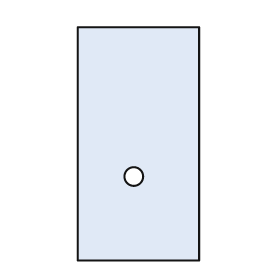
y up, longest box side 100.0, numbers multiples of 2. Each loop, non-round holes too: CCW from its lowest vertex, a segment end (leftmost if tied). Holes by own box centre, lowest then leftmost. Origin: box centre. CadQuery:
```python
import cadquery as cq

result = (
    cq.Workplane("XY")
    .moveTo(-26.0, -50.0)
    .lineTo(26.0, -50.0)
    .lineTo(26.0, 50.0)
    .lineTo(-26.0, 50.0)
    .close()
    .moveTo(-2.0, -14.0)
    .circle(4.0)
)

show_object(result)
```